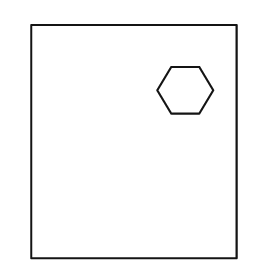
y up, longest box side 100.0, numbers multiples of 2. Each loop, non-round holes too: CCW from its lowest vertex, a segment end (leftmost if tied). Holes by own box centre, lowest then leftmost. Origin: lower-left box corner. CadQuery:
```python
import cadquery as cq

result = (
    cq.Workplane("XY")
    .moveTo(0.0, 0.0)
    .lineTo(88.0, 0.0)
    .lineTo(88.0, 100.0)
    .lineTo(0.0, 100.0)
    .close()
    .moveTo(60.0, 62.0)
    .lineTo(72.0, 62.0)
    .lineTo(78.0, 72.0)
    .lineTo(72.0, 82.0)
    .lineTo(60.0, 82.0)
    .lineTo(54.0, 72.0)
    .close()
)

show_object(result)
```